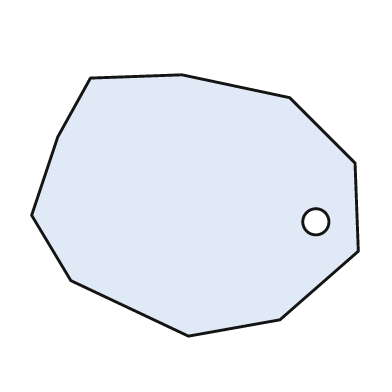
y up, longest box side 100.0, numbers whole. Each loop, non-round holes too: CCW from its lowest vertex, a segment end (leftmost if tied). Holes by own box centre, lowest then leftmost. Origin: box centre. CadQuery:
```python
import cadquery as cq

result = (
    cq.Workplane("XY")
    .moveTo(-2.0, -40.0)
    .lineTo(26.0, -35.0)
    .lineTo(50.0, -14.0)
    .lineTo(49.0, 13.0)
    .lineTo(29.0, 33.0)
    .lineTo(-4.0, 40.0)
    .lineTo(-32.0, 39.0)
    .lineTo(-42.0, 21.0)
    .lineTo(-50.0, -3.0)
    .lineTo(-38.0, -23.0)
    .close()
    .moveTo(37.0, -5.0)
    .circle(4.0)
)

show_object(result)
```